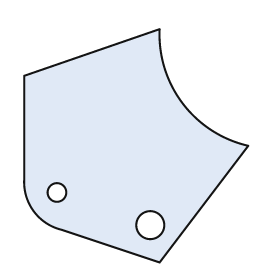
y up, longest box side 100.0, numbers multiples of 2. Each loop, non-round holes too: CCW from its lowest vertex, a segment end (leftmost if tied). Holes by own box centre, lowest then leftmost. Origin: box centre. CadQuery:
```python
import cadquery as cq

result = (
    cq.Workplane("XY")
    .moveTo(10.0, -50.0)
    .lineTo(48.0, 0.0)
    .threePointArc((20.0, 18.0), (10.0, 50.0))
    .lineTo(-48.0, 30.0)
    .lineTo(-48.0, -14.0)
    .threePointArc((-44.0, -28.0), (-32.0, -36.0))
    .close()
    .moveTo(6.0, -34.0)
    .circle(6.0)
    .moveTo(-34.0, -20.0)
    .circle(4.0)
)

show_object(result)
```